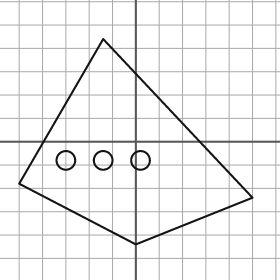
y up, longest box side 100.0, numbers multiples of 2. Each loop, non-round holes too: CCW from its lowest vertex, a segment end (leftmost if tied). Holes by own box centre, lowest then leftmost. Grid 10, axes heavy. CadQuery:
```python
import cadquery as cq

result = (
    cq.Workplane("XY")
    .moveTo(0.0, -44.0)
    .lineTo(50.0, -24.0)
    .lineTo(-14.0, 44.0)
    .lineTo(-50.0, -18.0)
    .close()
    .moveTo(-30.0, -8.0)
    .circle(4.0)
    .moveTo(-14.0, -8.0)
    .circle(4.0)
    .moveTo(2.0, -8.0)
    .circle(4.0)
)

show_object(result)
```